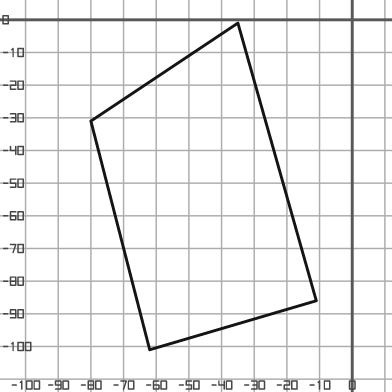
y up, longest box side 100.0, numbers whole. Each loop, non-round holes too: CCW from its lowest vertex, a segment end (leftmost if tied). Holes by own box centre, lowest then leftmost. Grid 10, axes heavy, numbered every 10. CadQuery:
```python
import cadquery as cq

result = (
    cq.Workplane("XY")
    .moveTo(-62.0, -101.0)
    .lineTo(-11.0, -86.0)
    .lineTo(-35.0, -1.0)
    .lineTo(-80.0, -31.0)
    .close()
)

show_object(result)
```